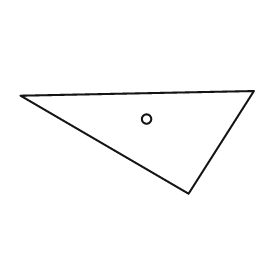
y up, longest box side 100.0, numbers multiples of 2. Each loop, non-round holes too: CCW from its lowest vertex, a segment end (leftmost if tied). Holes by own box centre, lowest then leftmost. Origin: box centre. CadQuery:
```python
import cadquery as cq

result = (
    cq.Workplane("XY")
    .moveTo(22.0, -22.0)
    .lineTo(50.0, 22.0)
    .lineTo(-50.0, 20.0)
    .close()
    .moveTo(4.0, 10.0)
    .circle(2.0)
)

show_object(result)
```